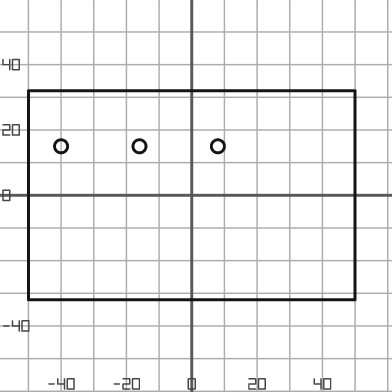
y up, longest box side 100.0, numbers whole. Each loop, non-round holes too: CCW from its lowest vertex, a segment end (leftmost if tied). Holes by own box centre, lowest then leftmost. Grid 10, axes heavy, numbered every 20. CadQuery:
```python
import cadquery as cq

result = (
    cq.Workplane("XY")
    .moveTo(-50.0, -32.0)
    .lineTo(50.0, -32.0)
    .lineTo(50.0, 32.0)
    .lineTo(-50.0, 32.0)
    .close()
    .moveTo(-40.0, 15.0)
    .circle(2.0)
    .moveTo(-16.0, 15.0)
    .circle(2.0)
    .moveTo(8.0, 15.0)
    .circle(2.0)
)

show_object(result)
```